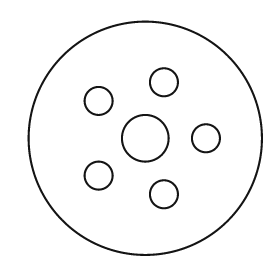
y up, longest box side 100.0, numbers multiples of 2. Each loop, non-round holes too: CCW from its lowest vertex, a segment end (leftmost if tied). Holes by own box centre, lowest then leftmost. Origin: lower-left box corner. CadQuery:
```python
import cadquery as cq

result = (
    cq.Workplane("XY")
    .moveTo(50.0, 50.0)
    .circle(50.0)
    .moveTo(58.0, 26.0)
    .circle(6.0)
    .moveTo(30.0, 34.0)
    .circle(6.0)
    .moveTo(50.0, 50.0)
    .circle(10.0)
    .moveTo(76.0, 50.0)
    .circle(6.0)
    .moveTo(30.0, 66.0)
    .circle(6.0)
    .moveTo(58.0, 74.0)
    .circle(6.0)
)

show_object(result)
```